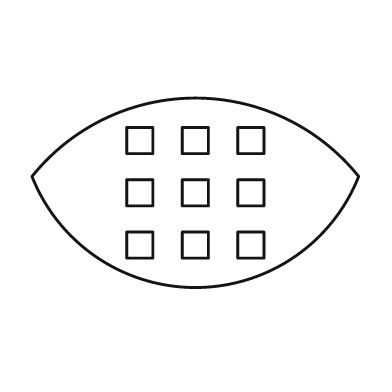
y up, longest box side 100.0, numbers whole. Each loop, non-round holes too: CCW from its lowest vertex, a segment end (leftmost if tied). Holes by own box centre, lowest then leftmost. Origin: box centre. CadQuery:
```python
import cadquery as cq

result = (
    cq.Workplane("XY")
    .moveTo(-50.0, 5.0)
    .threePointArc((0.0, -29.0), (50.0, 5.0))
    .threePointArc((0.0, 29.0), (-50.0, 5.0))
    .close()
    .moveTo(-21.0, -20.0)
    .lineTo(-13.0, -20.0)
    .lineTo(-13.0, -12.0)
    .lineTo(-21.0, -12.0)
    .close()
    .moveTo(-4.0, -20.0)
    .lineTo(4.0, -20.0)
    .lineTo(4.0, -12.0)
    .lineTo(-4.0, -12.0)
    .close()
    .moveTo(13.0, -20.0)
    .lineTo(21.0, -20.0)
    .lineTo(21.0, -12.0)
    .lineTo(13.0, -12.0)
    .close()
    .moveTo(-21.0, -4.0)
    .lineTo(-13.0, -4.0)
    .lineTo(-13.0, 4.0)
    .lineTo(-21.0, 4.0)
    .close()
    .moveTo(-4.0, -4.0)
    .lineTo(4.0, -4.0)
    .lineTo(4.0, 4.0)
    .lineTo(-4.0, 4.0)
    .close()
    .moveTo(13.0, -4.0)
    .lineTo(21.0, -4.0)
    .lineTo(21.0, 4.0)
    .lineTo(13.0, 4.0)
    .close()
    .moveTo(-21.0, 12.0)
    .lineTo(-13.0, 12.0)
    .lineTo(-13.0, 20.0)
    .lineTo(-21.0, 20.0)
    .close()
    .moveTo(-4.0, 12.0)
    .lineTo(4.0, 12.0)
    .lineTo(4.0, 20.0)
    .lineTo(-4.0, 20.0)
    .close()
    .moveTo(13.0, 12.0)
    .lineTo(21.0, 12.0)
    .lineTo(21.0, 20.0)
    .lineTo(13.0, 20.0)
    .close()
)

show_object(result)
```